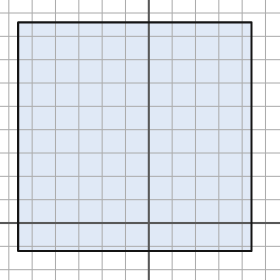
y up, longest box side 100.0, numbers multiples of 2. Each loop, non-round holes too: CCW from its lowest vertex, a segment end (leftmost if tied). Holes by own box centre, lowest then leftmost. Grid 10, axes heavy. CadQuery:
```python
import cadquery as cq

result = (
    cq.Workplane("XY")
    .moveTo(-56.0, -12.0)
    .lineTo(44.0, -12.0)
    .lineTo(44.0, 86.0)
    .lineTo(-56.0, 86.0)
    .close()
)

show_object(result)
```